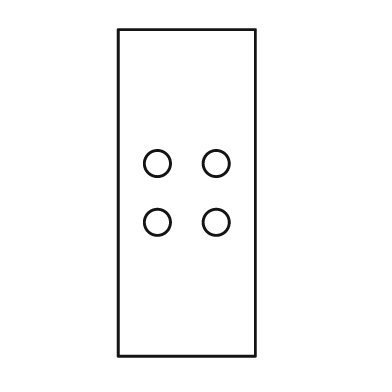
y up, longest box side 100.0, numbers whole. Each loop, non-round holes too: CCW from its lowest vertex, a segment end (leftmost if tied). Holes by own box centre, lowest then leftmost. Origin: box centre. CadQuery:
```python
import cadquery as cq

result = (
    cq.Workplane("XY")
    .moveTo(-21.0, -50.0)
    .lineTo(21.0, -50.0)
    .lineTo(21.0, 50.0)
    .lineTo(-21.0, 50.0)
    .close()
    .moveTo(-9.0, -9.0)
    .circle(4.0)
    .moveTo(9.0, -9.0)
    .circle(4.0)
    .moveTo(-9.0, 9.0)
    .circle(4.0)
    .moveTo(9.0, 9.0)
    .circle(4.0)
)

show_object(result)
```